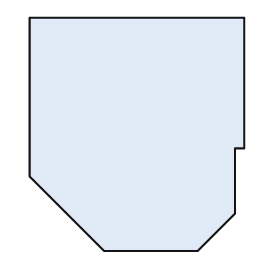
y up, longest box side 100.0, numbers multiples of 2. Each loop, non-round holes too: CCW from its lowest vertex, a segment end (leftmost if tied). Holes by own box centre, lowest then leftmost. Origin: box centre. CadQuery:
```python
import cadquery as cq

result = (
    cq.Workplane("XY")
    .moveTo(-14.0, -50.0)
    .lineTo(26.0, -50.0)
    .lineTo(42.0, -34.0)
    .lineTo(42.0, -6.0)
    .lineTo(46.0, -6.0)
    .lineTo(46.0, 50.0)
    .lineTo(-46.0, 50.0)
    .lineTo(-46.0, -18.0)
    .close()
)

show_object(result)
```